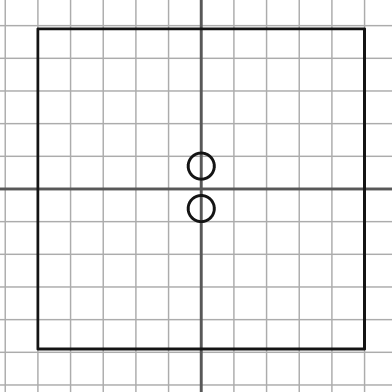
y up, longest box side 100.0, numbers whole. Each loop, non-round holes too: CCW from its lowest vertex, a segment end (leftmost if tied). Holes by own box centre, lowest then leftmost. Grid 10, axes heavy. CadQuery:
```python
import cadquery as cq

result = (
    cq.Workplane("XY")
    .moveTo(-50.0, -49.0)
    .lineTo(50.0, -49.0)
    .lineTo(50.0, 49.0)
    .lineTo(-50.0, 49.0)
    .close()
    .moveTo(0.0, -6.0)
    .circle(4.0)
    .moveTo(0.0, 7.0)
    .circle(4.0)
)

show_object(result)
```